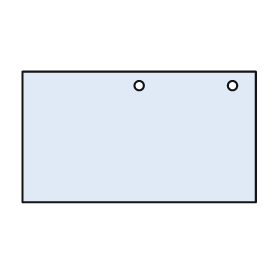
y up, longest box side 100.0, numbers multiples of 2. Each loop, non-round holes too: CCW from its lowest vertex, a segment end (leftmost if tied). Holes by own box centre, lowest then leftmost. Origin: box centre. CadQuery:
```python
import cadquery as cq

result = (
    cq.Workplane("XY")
    .moveTo(-50.0, -28.0)
    .lineTo(50.0, -28.0)
    .lineTo(50.0, 28.0)
    .lineTo(-50.0, 28.0)
    .close()
    .moveTo(0.0, 22.0)
    .circle(2.0)
    .moveTo(40.0, 22.0)
    .circle(2.0)
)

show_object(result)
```